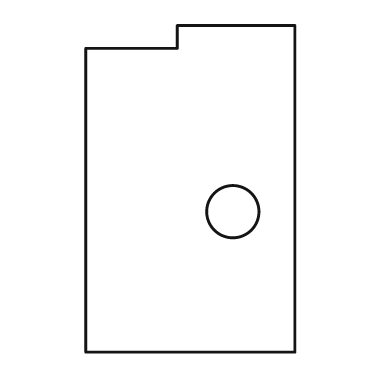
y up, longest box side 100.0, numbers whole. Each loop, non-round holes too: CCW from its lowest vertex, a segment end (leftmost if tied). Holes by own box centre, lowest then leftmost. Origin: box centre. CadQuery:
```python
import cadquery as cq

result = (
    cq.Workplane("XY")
    .moveTo(-32.0, -50.0)
    .lineTo(32.0, -50.0)
    .lineTo(32.0, 50.0)
    .lineTo(-4.0, 50.0)
    .lineTo(-4.0, 43.0)
    .lineTo(-32.0, 43.0)
    .close()
    .moveTo(13.0, -7.0)
    .circle(8.0)
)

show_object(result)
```